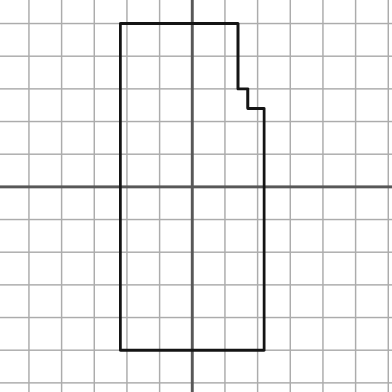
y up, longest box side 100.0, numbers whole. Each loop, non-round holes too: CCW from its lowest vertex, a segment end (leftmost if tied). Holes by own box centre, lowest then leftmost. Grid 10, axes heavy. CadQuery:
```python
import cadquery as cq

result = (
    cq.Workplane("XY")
    .moveTo(-22.0, -50.0)
    .lineTo(22.0, -50.0)
    .lineTo(22.0, 24.0)
    .lineTo(17.0, 24.0)
    .lineTo(17.0, 30.0)
    .lineTo(14.0, 30.0)
    .lineTo(14.0, 50.0)
    .lineTo(-22.0, 50.0)
    .close()
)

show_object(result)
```